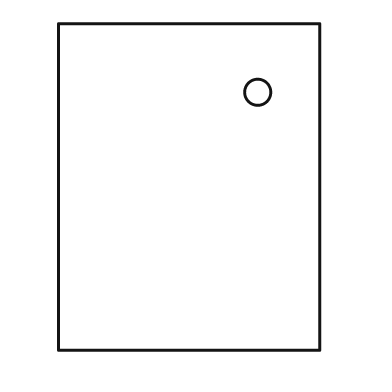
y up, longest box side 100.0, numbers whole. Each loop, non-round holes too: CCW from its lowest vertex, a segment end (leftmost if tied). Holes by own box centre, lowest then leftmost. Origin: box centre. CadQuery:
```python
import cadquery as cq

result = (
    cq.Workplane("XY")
    .moveTo(-40.0, -50.0)
    .lineTo(40.0, -50.0)
    .lineTo(40.0, 50.0)
    .lineTo(-40.0, 50.0)
    .close()
    .moveTo(21.0, 29.0)
    .circle(4.0)
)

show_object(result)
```